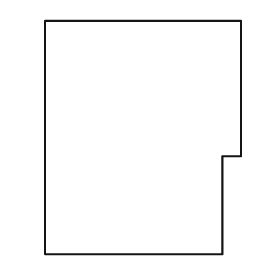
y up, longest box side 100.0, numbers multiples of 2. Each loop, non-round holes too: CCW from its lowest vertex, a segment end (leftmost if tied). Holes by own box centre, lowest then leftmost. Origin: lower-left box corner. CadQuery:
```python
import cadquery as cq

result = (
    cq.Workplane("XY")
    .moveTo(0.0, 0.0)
    .lineTo(76.0, 0.0)
    .lineTo(76.0, 42.0)
    .lineTo(84.0, 42.0)
    .lineTo(84.0, 100.0)
    .lineTo(0.0, 100.0)
    .close()
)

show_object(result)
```